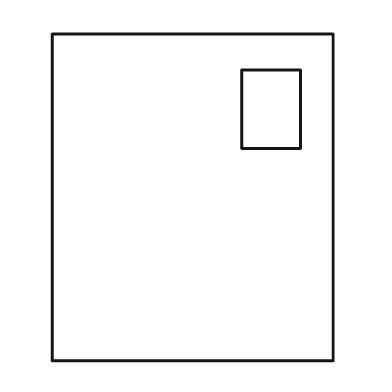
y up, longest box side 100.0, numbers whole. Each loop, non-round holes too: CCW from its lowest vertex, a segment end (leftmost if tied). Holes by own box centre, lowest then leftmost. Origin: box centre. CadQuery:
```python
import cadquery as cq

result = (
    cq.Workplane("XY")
    .moveTo(-43.0, -50.0)
    .lineTo(43.0, -50.0)
    .lineTo(43.0, 50.0)
    .lineTo(-43.0, 50.0)
    .close()
    .moveTo(15.0, 15.0)
    .lineTo(33.0, 15.0)
    .lineTo(33.0, 39.0)
    .lineTo(15.0, 39.0)
    .close()
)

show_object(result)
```